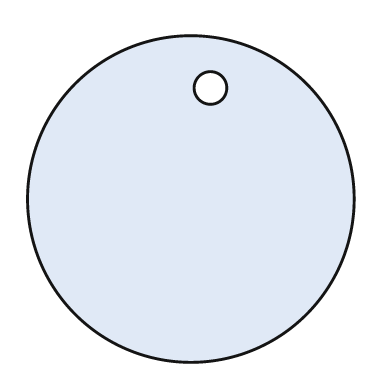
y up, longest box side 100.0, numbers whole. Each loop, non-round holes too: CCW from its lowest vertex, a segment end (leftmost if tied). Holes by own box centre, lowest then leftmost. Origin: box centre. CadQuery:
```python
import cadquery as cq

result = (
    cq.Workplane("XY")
    .moveTo(0.0, 0.0)
    .circle(50.0)
    .moveTo(6.0, 34.0)
    .circle(5.0)
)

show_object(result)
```